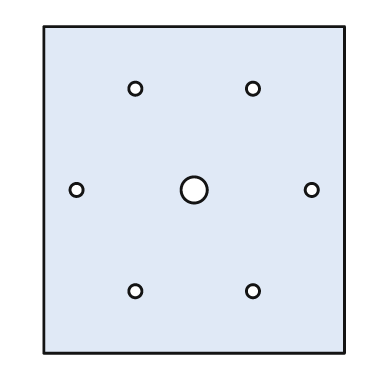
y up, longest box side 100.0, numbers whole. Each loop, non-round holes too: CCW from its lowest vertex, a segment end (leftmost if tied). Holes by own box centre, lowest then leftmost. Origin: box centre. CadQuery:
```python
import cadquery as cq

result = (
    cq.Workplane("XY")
    .moveTo(-46.0, -50.0)
    .lineTo(46.0, -50.0)
    .lineTo(46.0, 50.0)
    .lineTo(-46.0, 50.0)
    .close()
    .moveTo(-18.0, -31.0)
    .circle(2.0)
    .moveTo(18.0, -31.0)
    .circle(2.0)
    .moveTo(-36.0, 0.0)
    .circle(2.0)
    .moveTo(0.0, 0.0)
    .circle(4.0)
    .moveTo(36.0, 0.0)
    .circle(2.0)
    .moveTo(-18.0, 31.0)
    .circle(2.0)
    .moveTo(18.0, 31.0)
    .circle(2.0)
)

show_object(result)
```